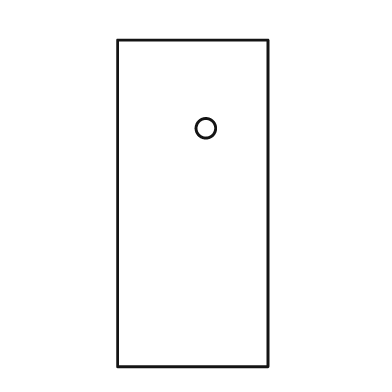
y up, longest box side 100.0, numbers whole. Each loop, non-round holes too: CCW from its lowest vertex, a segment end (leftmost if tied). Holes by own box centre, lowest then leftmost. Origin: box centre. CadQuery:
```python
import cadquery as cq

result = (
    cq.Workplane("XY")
    .moveTo(-23.0, -50.0)
    .lineTo(23.0, -50.0)
    .lineTo(23.0, 50.0)
    .lineTo(-23.0, 50.0)
    .close()
    .moveTo(4.0, 23.0)
    .circle(3.0)
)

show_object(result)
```